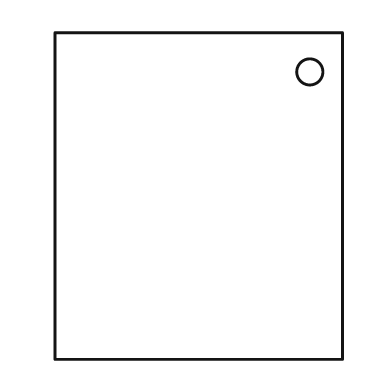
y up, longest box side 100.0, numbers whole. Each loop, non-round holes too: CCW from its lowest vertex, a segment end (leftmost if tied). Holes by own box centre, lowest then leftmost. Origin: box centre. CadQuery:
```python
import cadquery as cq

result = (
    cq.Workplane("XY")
    .moveTo(-44.0, -50.0)
    .lineTo(44.0, -50.0)
    .lineTo(44.0, 50.0)
    .lineTo(-44.0, 50.0)
    .close()
    .moveTo(34.0, 38.0)
    .circle(4.0)
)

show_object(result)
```